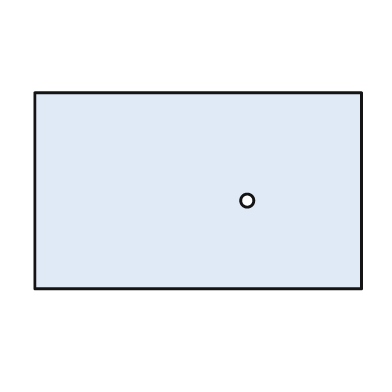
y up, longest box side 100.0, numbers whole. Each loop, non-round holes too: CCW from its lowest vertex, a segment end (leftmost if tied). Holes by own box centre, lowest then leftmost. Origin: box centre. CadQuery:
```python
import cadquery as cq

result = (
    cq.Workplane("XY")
    .moveTo(-50.0, -30.0)
    .lineTo(50.0, -30.0)
    .lineTo(50.0, 30.0)
    .lineTo(-50.0, 30.0)
    .close()
    .moveTo(15.0, -3.0)
    .circle(2.0)
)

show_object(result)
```